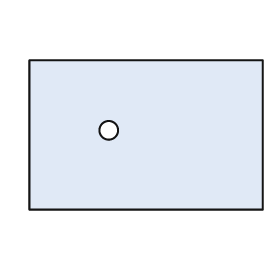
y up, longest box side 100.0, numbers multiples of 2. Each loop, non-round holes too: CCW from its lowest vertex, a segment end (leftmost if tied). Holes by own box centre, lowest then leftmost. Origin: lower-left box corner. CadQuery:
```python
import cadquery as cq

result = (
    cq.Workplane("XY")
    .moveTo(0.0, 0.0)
    .lineTo(100.0, 0.0)
    .lineTo(100.0, 64.0)
    .lineTo(0.0, 64.0)
    .close()
    .moveTo(34.0, 34.0)
    .circle(4.0)
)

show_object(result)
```